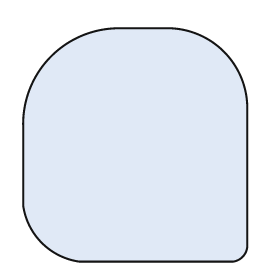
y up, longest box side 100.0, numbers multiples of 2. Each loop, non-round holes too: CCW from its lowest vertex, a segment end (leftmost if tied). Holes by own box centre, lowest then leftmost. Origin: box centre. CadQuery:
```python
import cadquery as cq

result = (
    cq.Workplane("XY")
    .moveTo(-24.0, -50.0)
    .lineTo(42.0, -50.0)
    .threePointArc((46.0, -48.0), (48.0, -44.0))
    .lineTo(48.0, 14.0)
    .threePointArc((38.0, 40.0), (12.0, 50.0))
    .lineTo(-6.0, 50.0)
    .threePointArc((-36.0, 38.0), (-48.0, 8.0))
    .lineTo(-48.0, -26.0)
    .threePointArc((-40.0, -42.0), (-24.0, -50.0))
    .close()
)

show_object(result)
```